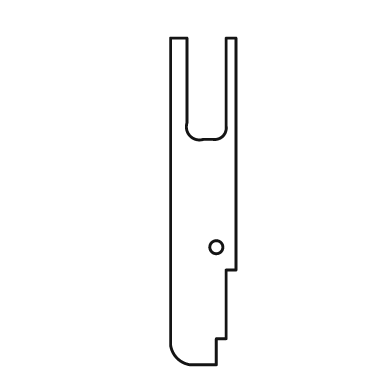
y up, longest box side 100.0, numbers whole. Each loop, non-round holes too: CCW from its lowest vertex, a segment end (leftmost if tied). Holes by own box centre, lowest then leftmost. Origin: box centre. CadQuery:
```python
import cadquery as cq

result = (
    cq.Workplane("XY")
    .moveTo(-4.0, -50.0)
    .lineTo(4.0, -50.0)
    .lineTo(4.0, -42.0)
    .lineTo(7.0, -42.0)
    .lineTo(7.0, -21.0)
    .lineTo(10.0, -21.0)
    .lineTo(10.0, 50.0)
    .lineTo(7.0, 50.0)
    .lineTo(7.0, 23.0)
    .threePointArc((6.0, 20.0), (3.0, 19.0))
    .lineTo(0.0, 19.0)
    .threePointArc((-4.0, 20.0), (-5.0, 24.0))
    .lineTo(-5.0, 50.0)
    .lineTo(-10.0, 50.0)
    .lineTo(-10.0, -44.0)
    .threePointArc((-8.0, -48.0), (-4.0, -50.0))
    .close()
    .moveTo(4.0, -14.0)
    .circle(2.0)
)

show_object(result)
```